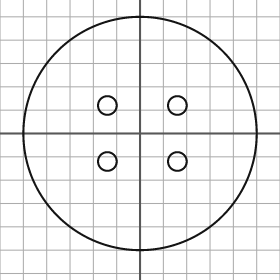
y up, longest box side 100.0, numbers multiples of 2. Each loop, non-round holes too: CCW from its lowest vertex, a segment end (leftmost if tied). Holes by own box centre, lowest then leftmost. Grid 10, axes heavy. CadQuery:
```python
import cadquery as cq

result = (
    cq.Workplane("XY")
    .moveTo(0.0, 0.0)
    .circle(50.0)
    .moveTo(-14.0, -12.0)
    .circle(4.0)
    .moveTo(16.0, -12.0)
    .circle(4.0)
    .moveTo(-14.0, 12.0)
    .circle(4.0)
    .moveTo(16.0, 12.0)
    .circle(4.0)
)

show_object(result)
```